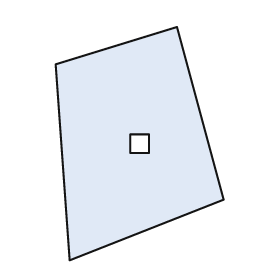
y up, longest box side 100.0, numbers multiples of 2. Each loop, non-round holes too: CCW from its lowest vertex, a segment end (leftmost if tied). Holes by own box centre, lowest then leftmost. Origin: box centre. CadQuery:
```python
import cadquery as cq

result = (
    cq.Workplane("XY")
    .moveTo(-30.0, -50.0)
    .lineTo(36.0, -24.0)
    .lineTo(16.0, 50.0)
    .lineTo(-36.0, 34.0)
    .close()
    .moveTo(-4.0, -4.0)
    .lineTo(4.0, -4.0)
    .lineTo(4.0, 4.0)
    .lineTo(-4.0, 4.0)
    .close()
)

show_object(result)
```